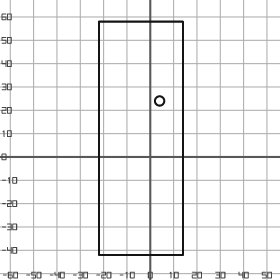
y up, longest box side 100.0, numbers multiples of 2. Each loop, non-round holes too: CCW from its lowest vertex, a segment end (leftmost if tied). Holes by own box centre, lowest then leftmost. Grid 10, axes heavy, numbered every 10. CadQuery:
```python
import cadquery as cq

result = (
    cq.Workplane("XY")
    .moveTo(-22.0, -42.0)
    .lineTo(14.0, -42.0)
    .lineTo(14.0, 58.0)
    .lineTo(-22.0, 58.0)
    .close()
    .moveTo(4.0, 24.0)
    .circle(2.0)
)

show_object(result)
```